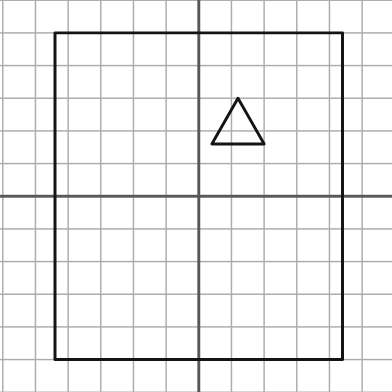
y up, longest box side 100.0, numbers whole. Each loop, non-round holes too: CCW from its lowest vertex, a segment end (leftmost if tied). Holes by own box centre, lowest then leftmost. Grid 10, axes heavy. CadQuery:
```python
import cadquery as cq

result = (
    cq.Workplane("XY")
    .moveTo(-44.0, -50.0)
    .lineTo(44.0, -50.0)
    .lineTo(44.0, 50.0)
    .lineTo(-44.0, 50.0)
    .close()
    .moveTo(4.0, 16.0)
    .lineTo(20.0, 16.0)
    .lineTo(12.0, 30.0)
    .close()
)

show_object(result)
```